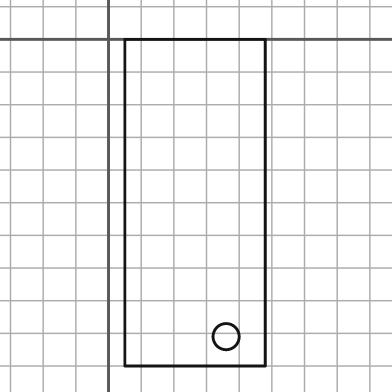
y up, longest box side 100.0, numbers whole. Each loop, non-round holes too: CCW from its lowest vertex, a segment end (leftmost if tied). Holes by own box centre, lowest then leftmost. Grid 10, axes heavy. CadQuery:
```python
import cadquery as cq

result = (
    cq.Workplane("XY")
    .moveTo(5.0, -100.0)
    .lineTo(48.0, -100.0)
    .lineTo(48.0, 0.0)
    .lineTo(5.0, 0.0)
    .close()
    .moveTo(36.0, -91.0)
    .circle(4.0)
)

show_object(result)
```